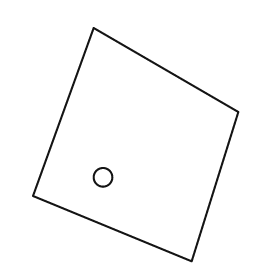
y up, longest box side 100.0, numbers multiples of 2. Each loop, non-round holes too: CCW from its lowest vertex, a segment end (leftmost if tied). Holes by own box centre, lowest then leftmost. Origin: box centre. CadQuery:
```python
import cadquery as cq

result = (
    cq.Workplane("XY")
    .moveTo(24.0, -50.0)
    .lineTo(44.0, 14.0)
    .lineTo(-18.0, 50.0)
    .lineTo(-44.0, -22.0)
    .close()
    .moveTo(-14.0, -14.0)
    .circle(4.0)
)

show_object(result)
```